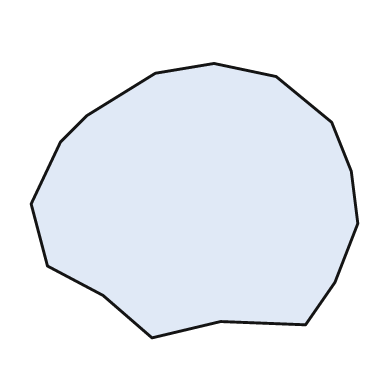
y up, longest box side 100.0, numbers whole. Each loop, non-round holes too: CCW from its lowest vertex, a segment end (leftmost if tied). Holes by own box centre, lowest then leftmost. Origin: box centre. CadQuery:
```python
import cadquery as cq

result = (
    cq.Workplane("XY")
    .moveTo(-13.0, -42.0)
    .lineTo(8.0, -37.0)
    .lineTo(34.0, -38.0)
    .lineTo(43.0, -25.0)
    .lineTo(50.0, -7.0)
    .lineTo(48.0, 9.0)
    .lineTo(42.0, 24.0)
    .lineTo(25.0, 38.0)
    .lineTo(6.0, 42.0)
    .lineTo(-12.0, 39.0)
    .lineTo(-33.0, 26.0)
    .lineTo(-41.0, 18.0)
    .lineTo(-50.0, -1.0)
    .lineTo(-45.0, -20.0)
    .lineTo(-28.0, -29.0)
    .close()
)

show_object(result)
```